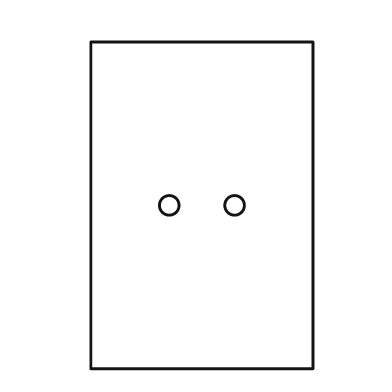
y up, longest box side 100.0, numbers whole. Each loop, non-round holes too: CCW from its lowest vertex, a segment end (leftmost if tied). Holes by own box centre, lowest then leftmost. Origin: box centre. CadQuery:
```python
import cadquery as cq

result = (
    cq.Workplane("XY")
    .moveTo(-34.0, -50.0)
    .lineTo(34.0, -50.0)
    .lineTo(34.0, 50.0)
    .lineTo(-34.0, 50.0)
    .close()
    .moveTo(-10.0, 0.0)
    .circle(3.0)
    .moveTo(10.0, 0.0)
    .circle(3.0)
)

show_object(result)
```